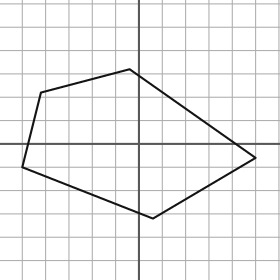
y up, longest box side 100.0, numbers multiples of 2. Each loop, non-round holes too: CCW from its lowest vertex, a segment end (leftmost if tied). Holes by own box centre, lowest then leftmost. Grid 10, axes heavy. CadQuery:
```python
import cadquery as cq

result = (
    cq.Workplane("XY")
    .moveTo(6.0, -32.0)
    .lineTo(50.0, -6.0)
    .lineTo(-4.0, 32.0)
    .lineTo(-42.0, 22.0)
    .lineTo(-50.0, -10.0)
    .close()
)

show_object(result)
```